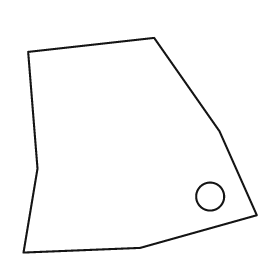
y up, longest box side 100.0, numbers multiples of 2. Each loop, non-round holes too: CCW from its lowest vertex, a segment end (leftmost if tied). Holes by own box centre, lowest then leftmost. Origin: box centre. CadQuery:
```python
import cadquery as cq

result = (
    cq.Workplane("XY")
    .moveTo(-50.0, -46.0)
    .lineTo(0.0, -44.0)
    .lineTo(50.0, -30.0)
    .lineTo(34.0, 6.0)
    .lineTo(6.0, 46.0)
    .lineTo(-48.0, 40.0)
    .lineTo(-44.0, -10.0)
    .close()
    .moveTo(30.0, -22.0)
    .circle(6.0)
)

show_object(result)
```